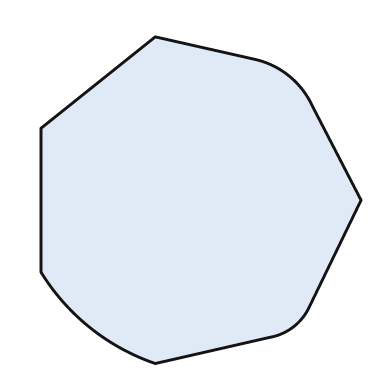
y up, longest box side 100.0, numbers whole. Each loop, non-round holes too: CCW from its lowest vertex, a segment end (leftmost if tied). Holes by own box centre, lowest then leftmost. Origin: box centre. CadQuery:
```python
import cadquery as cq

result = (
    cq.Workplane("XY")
    .moveTo(-14.0, -50.0)
    .lineTo(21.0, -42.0)
    .threePointArc((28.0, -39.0), (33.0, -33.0))
    .lineTo(49.0, 0.0)
    .lineTo(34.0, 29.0)
    .threePointArc((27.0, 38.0), (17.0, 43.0))
    .lineTo(-14.0, 50.0)
    .lineTo(-49.0, 22.0)
    .lineTo(-49.0, -22.0)
    .threePointArc((-34.0, -39.0), (-14.0, -50.0))
    .close()
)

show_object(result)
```